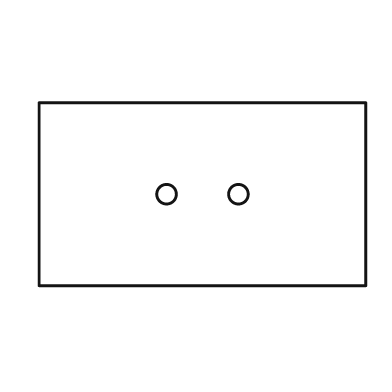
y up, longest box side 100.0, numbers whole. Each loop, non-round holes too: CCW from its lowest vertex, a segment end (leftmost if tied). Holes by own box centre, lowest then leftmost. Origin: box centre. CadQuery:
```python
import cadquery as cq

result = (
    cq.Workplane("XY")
    .moveTo(-50.0, -28.0)
    .lineTo(50.0, -28.0)
    .lineTo(50.0, 28.0)
    .lineTo(-50.0, 28.0)
    .close()
    .moveTo(-11.0, 0.0)
    .circle(3.0)
    .moveTo(11.0, 0.0)
    .circle(3.0)
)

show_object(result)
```